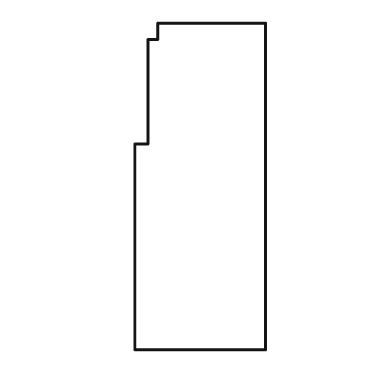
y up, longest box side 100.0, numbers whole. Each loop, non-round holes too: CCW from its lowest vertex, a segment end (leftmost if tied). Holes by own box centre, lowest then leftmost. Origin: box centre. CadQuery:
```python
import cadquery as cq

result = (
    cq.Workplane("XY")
    .moveTo(-20.0, -50.0)
    .lineTo(20.0, -50.0)
    .lineTo(20.0, 50.0)
    .lineTo(-13.0, 50.0)
    .lineTo(-13.0, 45.0)
    .lineTo(-16.0, 45.0)
    .lineTo(-16.0, 13.0)
    .lineTo(-20.0, 13.0)
    .close()
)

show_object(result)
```